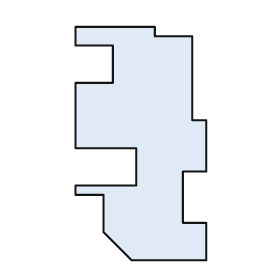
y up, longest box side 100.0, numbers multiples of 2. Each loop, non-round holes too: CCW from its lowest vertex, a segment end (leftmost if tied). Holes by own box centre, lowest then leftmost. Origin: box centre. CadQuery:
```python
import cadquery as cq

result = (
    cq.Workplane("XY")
    .moveTo(-4.0, -50.0)
    .lineTo(28.0, -50.0)
    .lineTo(28.0, -34.0)
    .lineTo(18.0, -34.0)
    .lineTo(18.0, -12.0)
    .lineTo(28.0, -12.0)
    .lineTo(28.0, 10.0)
    .lineTo(22.0, 10.0)
    .lineTo(22.0, 46.0)
    .lineTo(6.0, 46.0)
    .lineTo(6.0, 50.0)
    .lineTo(-28.0, 50.0)
    .lineTo(-28.0, 42.0)
    .lineTo(-12.0, 42.0)
    .lineTo(-12.0, 26.0)
    .lineTo(-28.0, 26.0)
    .lineTo(-28.0, -2.0)
    .lineTo(-2.0, -2.0)
    .lineTo(-2.0, -18.0)
    .lineTo(-28.0, -18.0)
    .lineTo(-28.0, -22.0)
    .lineTo(-16.0, -22.0)
    .lineTo(-16.0, -38.0)
    .close()
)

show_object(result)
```